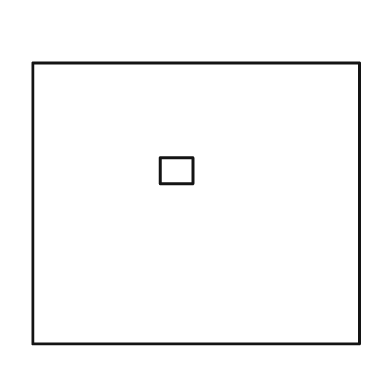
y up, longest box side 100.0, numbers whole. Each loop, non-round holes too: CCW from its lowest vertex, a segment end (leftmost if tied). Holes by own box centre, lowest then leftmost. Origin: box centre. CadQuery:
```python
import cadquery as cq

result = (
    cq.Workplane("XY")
    .moveTo(-50.0, -43.0)
    .lineTo(50.0, -43.0)
    .lineTo(50.0, 43.0)
    .lineTo(-50.0, 43.0)
    .close()
    .moveTo(-11.0, 6.0)
    .lineTo(-1.0, 6.0)
    .lineTo(-1.0, 14.0)
    .lineTo(-11.0, 14.0)
    .close()
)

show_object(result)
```